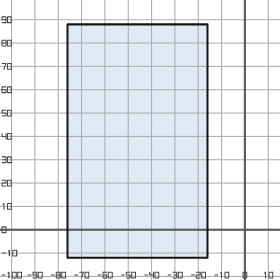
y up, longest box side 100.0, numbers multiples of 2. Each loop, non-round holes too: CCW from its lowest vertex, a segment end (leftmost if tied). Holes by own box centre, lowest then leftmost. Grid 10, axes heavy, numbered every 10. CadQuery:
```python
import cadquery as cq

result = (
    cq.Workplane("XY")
    .moveTo(-76.0, -12.0)
    .lineTo(-16.0, -12.0)
    .lineTo(-16.0, 88.0)
    .lineTo(-76.0, 88.0)
    .close()
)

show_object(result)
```